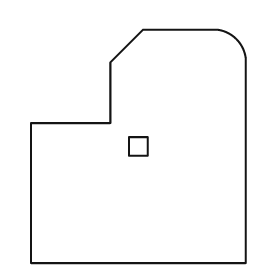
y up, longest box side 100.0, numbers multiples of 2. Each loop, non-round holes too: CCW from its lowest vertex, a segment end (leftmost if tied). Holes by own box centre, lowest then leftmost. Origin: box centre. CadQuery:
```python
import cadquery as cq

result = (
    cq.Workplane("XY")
    .moveTo(-46.0, -50.0)
    .lineTo(46.0, -50.0)
    .lineTo(46.0, 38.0)
    .threePointArc((42.0, 46.0), (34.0, 50.0))
    .lineTo(2.0, 50.0)
    .lineTo(-12.0, 36.0)
    .lineTo(-12.0, 10.0)
    .lineTo(-46.0, 10.0)
    .close()
    .moveTo(-4.0, -4.0)
    .lineTo(4.0, -4.0)
    .lineTo(4.0, 4.0)
    .lineTo(-4.0, 4.0)
    .close()
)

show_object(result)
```